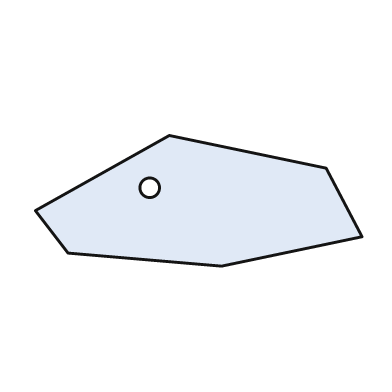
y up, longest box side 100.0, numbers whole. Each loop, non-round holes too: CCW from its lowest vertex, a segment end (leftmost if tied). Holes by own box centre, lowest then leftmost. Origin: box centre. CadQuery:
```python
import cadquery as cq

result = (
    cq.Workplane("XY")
    .moveTo(7.0, -20.0)
    .lineTo(50.0, -11.0)
    .lineTo(39.0, 10.0)
    .lineTo(-9.0, 20.0)
    .lineTo(-50.0, -3.0)
    .lineTo(-40.0, -16.0)
    .close()
    .moveTo(-15.0, 4.0)
    .circle(3.0)
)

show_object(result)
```